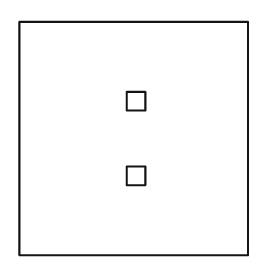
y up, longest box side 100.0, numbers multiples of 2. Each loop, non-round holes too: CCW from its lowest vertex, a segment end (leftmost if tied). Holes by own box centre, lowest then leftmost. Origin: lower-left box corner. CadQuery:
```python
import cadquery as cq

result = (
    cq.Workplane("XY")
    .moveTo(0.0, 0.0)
    .lineTo(98.0, 0.0)
    .lineTo(98.0, 100.0)
    .lineTo(0.0, 100.0)
    .close()
    .moveTo(46.0, 30.0)
    .lineTo(54.0, 30.0)
    .lineTo(54.0, 38.0)
    .lineTo(46.0, 38.0)
    .close()
    .moveTo(46.0, 62.0)
    .lineTo(54.0, 62.0)
    .lineTo(54.0, 70.0)
    .lineTo(46.0, 70.0)
    .close()
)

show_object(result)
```